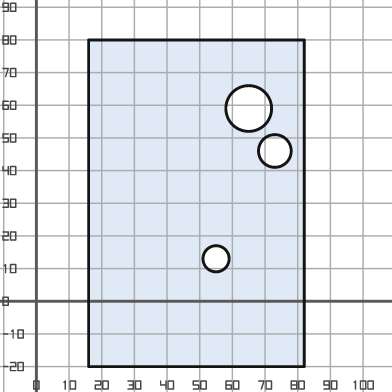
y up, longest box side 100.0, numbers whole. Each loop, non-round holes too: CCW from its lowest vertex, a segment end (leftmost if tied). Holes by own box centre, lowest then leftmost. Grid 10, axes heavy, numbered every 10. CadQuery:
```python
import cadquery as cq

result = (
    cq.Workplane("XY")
    .moveTo(16.0, -20.0)
    .lineTo(82.0, -20.0)
    .lineTo(82.0, 80.0)
    .lineTo(16.0, 80.0)
    .close()
    .moveTo(55.0, 13.0)
    .circle(4.0)
    .moveTo(73.0, 46.0)
    .circle(5.0)
    .moveTo(65.0, 59.0)
    .circle(7.0)
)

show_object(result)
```